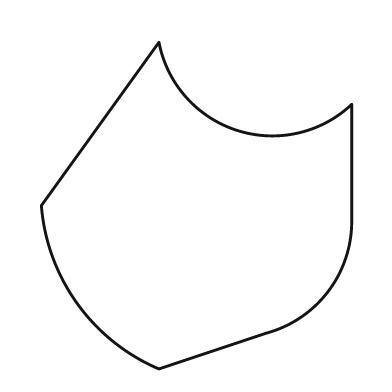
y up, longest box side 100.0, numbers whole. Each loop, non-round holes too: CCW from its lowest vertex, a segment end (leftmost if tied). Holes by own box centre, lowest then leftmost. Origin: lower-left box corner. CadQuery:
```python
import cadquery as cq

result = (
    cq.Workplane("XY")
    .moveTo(36.0, 0.0)
    .lineTo(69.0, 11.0)
    .threePointArc((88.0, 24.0), (95.0, 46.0))
    .lineTo(95.0, 81.0)
    .threePointArc((60.0, 73.0), (36.0, 100.0))
    .lineTo(0.0, 50.0)
    .threePointArc((11.0, 20.0), (36.0, 0.0))
    .close()
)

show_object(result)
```